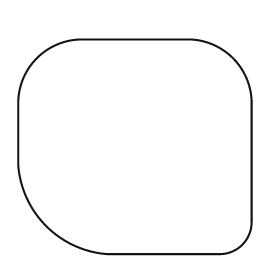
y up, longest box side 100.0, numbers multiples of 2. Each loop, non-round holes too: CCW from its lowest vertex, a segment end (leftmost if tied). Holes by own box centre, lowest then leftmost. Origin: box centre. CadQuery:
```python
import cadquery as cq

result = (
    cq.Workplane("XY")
    .moveTo(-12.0, -46.0)
    .lineTo(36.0, -46.0)
    .threePointArc((46.0, -42.0), (50.0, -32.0))
    .lineTo(50.0, 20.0)
    .threePointArc((42.0, 38.0), (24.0, 46.0))
    .lineTo(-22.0, 46.0)
    .threePointArc((-42.0, 38.0), (-50.0, 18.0))
    .lineTo(-50.0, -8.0)
    .threePointArc((-38.0, -34.0), (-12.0, -46.0))
    .close()
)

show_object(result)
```